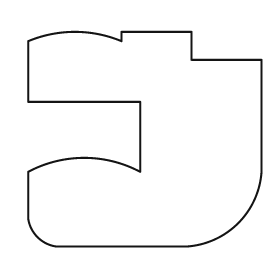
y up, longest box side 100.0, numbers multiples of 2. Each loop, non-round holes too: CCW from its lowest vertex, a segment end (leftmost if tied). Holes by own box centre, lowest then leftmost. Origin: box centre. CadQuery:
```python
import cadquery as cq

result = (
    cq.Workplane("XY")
    .moveTo(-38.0, -46.0)
    .lineTo(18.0, -46.0)
    .threePointArc((40.0, -36.0), (50.0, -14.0))
    .lineTo(50.0, 34.0)
    .lineTo(20.0, 34.0)
    .lineTo(20.0, 46.0)
    .lineTo(-10.0, 46.0)
    .lineTo(-10.0, 42.0)
    .threePointArc((-30.0, 46.0), (-50.0, 42.0))
    .lineTo(-50.0, 16.0)
    .lineTo(-2.0, 16.0)
    .lineTo(-2.0, -14.0)
    .threePointArc((-26.0, -8.0), (-50.0, -14.0))
    .lineTo(-50.0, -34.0)
    .threePointArc((-46.0, -42.0), (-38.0, -46.0))
    .close()
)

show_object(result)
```